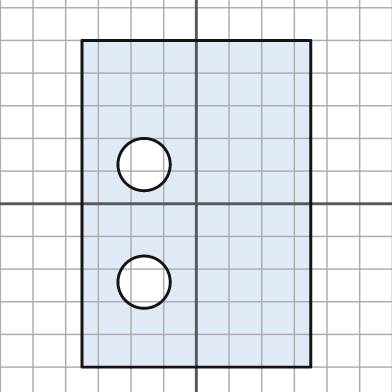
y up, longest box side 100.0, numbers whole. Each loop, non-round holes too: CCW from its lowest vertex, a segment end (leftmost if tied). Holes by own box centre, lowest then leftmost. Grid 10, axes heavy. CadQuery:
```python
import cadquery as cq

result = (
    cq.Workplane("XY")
    .moveTo(-35.0, -50.0)
    .lineTo(35.0, -50.0)
    .lineTo(35.0, 50.0)
    .lineTo(-35.0, 50.0)
    .close()
    .moveTo(-16.0, -24.0)
    .circle(8.0)
    .moveTo(-16.0, 12.0)
    .circle(8.0)
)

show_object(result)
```